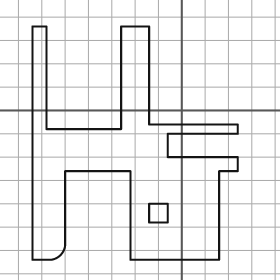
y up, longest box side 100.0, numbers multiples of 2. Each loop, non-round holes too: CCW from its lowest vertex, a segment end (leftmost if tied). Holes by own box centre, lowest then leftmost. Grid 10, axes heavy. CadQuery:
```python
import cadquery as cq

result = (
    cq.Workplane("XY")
    .moveTo(-64.0, -64.0)
    .lineTo(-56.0, -64.0)
    .threePointArc((-52.0, -62.0), (-50.0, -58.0))
    .lineTo(-50.0, -26.0)
    .lineTo(-22.0, -26.0)
    .lineTo(-22.0, -64.0)
    .lineTo(16.0, -64.0)
    .lineTo(16.0, -26.0)
    .lineTo(24.0, -26.0)
    .lineTo(24.0, -20.0)
    .lineTo(-6.0, -20.0)
    .lineTo(-6.0, -10.0)
    .lineTo(24.0, -10.0)
    .lineTo(24.0, -6.0)
    .lineTo(-14.0, -6.0)
    .lineTo(-14.0, 36.0)
    .lineTo(-26.0, 36.0)
    .lineTo(-26.0, -8.0)
    .lineTo(-58.0, -8.0)
    .lineTo(-58.0, 36.0)
    .lineTo(-64.0, 36.0)
    .close()
    .moveTo(-14.0, -48.0)
    .lineTo(-6.0, -48.0)
    .lineTo(-6.0, -40.0)
    .lineTo(-14.0, -40.0)
    .close()
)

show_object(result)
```